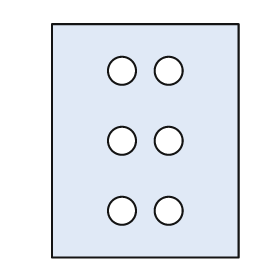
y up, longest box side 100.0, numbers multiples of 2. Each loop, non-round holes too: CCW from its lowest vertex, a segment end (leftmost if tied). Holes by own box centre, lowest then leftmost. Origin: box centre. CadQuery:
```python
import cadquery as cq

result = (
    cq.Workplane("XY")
    .moveTo(-40.0, -50.0)
    .lineTo(40.0, -50.0)
    .lineTo(40.0, 50.0)
    .lineTo(-40.0, 50.0)
    .close()
    .moveTo(-10.0, -30.0)
    .circle(6.0)
    .moveTo(10.0, -30.0)
    .circle(6.0)
    .moveTo(-10.0, 0.0)
    .circle(6.0)
    .moveTo(10.0, 0.0)
    .circle(6.0)
    .moveTo(-10.0, 30.0)
    .circle(6.0)
    .moveTo(10.0, 30.0)
    .circle(6.0)
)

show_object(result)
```